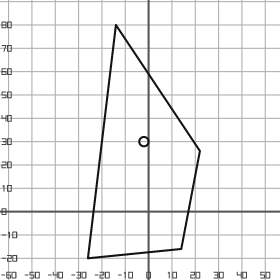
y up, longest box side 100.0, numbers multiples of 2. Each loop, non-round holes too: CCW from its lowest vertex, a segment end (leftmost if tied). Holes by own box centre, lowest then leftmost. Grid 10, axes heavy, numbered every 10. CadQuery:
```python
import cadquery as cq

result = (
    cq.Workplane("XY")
    .moveTo(-26.0, -20.0)
    .lineTo(14.0, -16.0)
    .lineTo(22.0, 26.0)
    .lineTo(-14.0, 80.0)
    .close()
    .moveTo(-2.0, 30.0)
    .circle(2.0)
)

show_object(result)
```